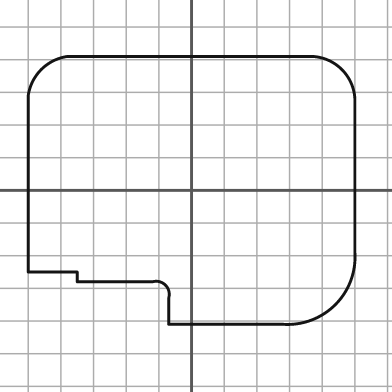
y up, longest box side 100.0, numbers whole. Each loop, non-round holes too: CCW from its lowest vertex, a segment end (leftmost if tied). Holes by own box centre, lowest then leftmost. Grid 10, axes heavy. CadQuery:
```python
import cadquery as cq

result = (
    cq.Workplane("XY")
    .moveTo(-7.0, -41.0)
    .lineTo(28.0, -41.0)
    .threePointArc((44.0, -35.0), (50.0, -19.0))
    .lineTo(50.0, 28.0)
    .threePointArc((46.0, 37.0), (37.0, 41.0))
    .lineTo(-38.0, 41.0)
    .threePointArc((-46.0, 37.0), (-50.0, 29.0))
    .lineTo(-50.0, -25.0)
    .lineTo(-35.0, -25.0)
    .lineTo(-35.0, -28.0)
    .lineTo(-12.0, -28.0)
    .threePointArc((-8.0, -29.0), (-7.0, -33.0))
    .close()
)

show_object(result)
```